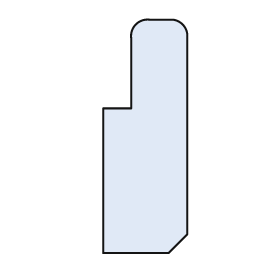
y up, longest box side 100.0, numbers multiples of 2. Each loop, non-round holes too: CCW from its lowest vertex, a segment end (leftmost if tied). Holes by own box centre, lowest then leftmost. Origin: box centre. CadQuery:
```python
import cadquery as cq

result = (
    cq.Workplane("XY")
    .moveTo(-18.0, -50.0)
    .lineTo(10.0, -50.0)
    .lineTo(18.0, -42.0)
    .lineTo(18.0, 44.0)
    .threePointArc((16.0, 48.0), (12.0, 50.0))
    .lineTo(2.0, 50.0)
    .threePointArc((-4.0, 48.0), (-6.0, 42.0))
    .lineTo(-6.0, 12.0)
    .lineTo(-18.0, 12.0)
    .close()
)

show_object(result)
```